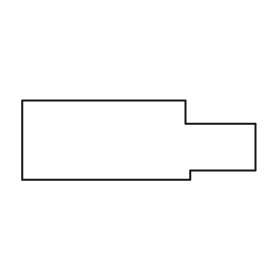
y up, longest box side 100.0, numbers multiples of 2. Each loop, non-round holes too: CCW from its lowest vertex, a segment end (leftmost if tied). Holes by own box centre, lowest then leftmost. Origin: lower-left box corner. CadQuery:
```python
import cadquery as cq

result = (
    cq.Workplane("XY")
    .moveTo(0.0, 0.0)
    .lineTo(72.0, 0.0)
    .lineTo(72.0, 4.0)
    .lineTo(100.0, 4.0)
    .lineTo(100.0, 24.0)
    .lineTo(70.0, 24.0)
    .lineTo(70.0, 34.0)
    .lineTo(0.0, 34.0)
    .close()
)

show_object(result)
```